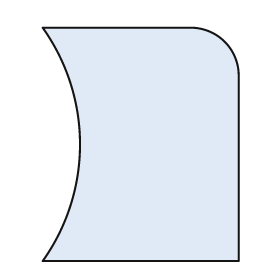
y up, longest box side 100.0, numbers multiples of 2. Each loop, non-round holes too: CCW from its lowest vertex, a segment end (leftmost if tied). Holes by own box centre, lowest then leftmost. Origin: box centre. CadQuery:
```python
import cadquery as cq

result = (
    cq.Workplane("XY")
    .moveTo(-42.0, -50.0)
    .lineTo(42.0, -50.0)
    .lineTo(42.0, 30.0)
    .threePointArc((36.0, 44.0), (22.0, 50.0))
    .lineTo(-42.0, 50.0)
    .threePointArc((-26.0, 0.0), (-42.0, -50.0))
    .close()
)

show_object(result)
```